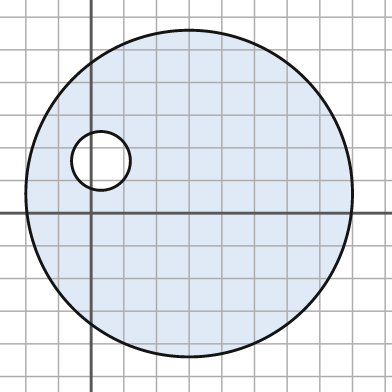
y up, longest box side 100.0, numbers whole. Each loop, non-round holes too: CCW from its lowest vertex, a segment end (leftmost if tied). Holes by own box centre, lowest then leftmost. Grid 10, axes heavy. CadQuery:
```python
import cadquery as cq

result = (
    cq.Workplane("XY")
    .moveTo(30.0, 6.0)
    .circle(50.0)
    .moveTo(3.0, 16.0)
    .circle(9.0)
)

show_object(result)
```